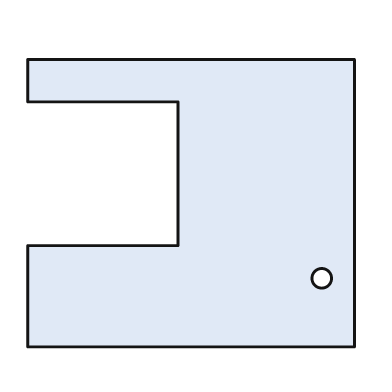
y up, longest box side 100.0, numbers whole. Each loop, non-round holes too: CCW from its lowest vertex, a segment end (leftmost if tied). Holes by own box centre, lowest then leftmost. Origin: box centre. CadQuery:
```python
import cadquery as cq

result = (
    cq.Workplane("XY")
    .moveTo(-50.0, -44.0)
    .lineTo(50.0, -44.0)
    .lineTo(50.0, 44.0)
    .lineTo(-50.0, 44.0)
    .lineTo(-50.0, 31.0)
    .lineTo(-4.0, 31.0)
    .lineTo(-4.0, -13.0)
    .lineTo(-50.0, -13.0)
    .close()
    .moveTo(40.0, -23.0)
    .circle(3.0)
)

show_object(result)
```